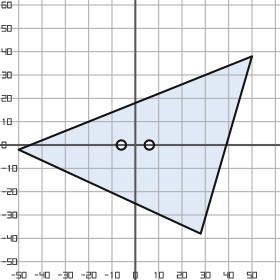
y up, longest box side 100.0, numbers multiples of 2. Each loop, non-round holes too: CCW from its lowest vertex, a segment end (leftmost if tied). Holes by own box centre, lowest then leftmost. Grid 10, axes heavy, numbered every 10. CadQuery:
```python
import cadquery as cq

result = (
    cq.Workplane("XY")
    .moveTo(28.0, -38.0)
    .lineTo(50.0, 38.0)
    .lineTo(-50.0, -2.0)
    .close()
    .moveTo(-6.0, 0.0)
    .circle(2.0)
    .moveTo(6.0, 0.0)
    .circle(2.0)
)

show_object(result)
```